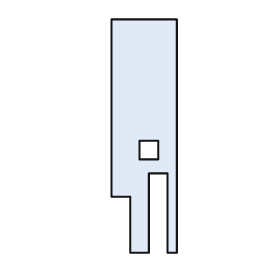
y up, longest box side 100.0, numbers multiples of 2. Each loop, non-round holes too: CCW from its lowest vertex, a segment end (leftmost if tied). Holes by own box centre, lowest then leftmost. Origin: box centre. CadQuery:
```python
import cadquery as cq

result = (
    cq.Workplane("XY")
    .moveTo(-6.0, -50.0)
    .lineTo(2.0, -50.0)
    .lineTo(2.0, -16.0)
    .lineTo(10.0, -16.0)
    .lineTo(10.0, -50.0)
    .lineTo(14.0, -50.0)
    .lineTo(14.0, 50.0)
    .lineTo(-14.0, 50.0)
    .lineTo(-14.0, -26.0)
    .lineTo(-6.0, -26.0)
    .close()
    .moveTo(-2.0, -10.0)
    .lineTo(6.0, -10.0)
    .lineTo(6.0, -2.0)
    .lineTo(-2.0, -2.0)
    .close()
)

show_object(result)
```